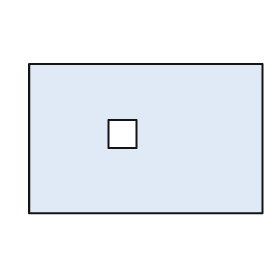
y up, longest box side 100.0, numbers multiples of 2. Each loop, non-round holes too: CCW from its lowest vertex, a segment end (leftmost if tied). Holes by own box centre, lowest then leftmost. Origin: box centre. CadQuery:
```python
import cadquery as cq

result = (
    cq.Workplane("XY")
    .moveTo(-50.0, -32.0)
    .lineTo(50.0, -32.0)
    .lineTo(50.0, 32.0)
    .lineTo(-50.0, 32.0)
    .close()
    .moveTo(-16.0, -4.0)
    .lineTo(-4.0, -4.0)
    .lineTo(-4.0, 8.0)
    .lineTo(-16.0, 8.0)
    .close()
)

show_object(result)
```